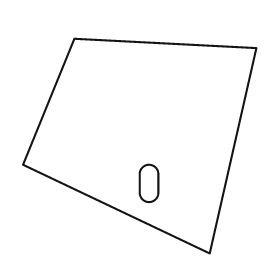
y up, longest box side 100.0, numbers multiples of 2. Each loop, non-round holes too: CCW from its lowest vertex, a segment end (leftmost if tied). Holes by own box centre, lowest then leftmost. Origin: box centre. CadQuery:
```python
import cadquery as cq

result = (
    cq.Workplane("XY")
    .moveTo(30.0, -46.0)
    .lineTo(50.0, 42.0)
    .lineTo(-28.0, 46.0)
    .lineTo(-50.0, -8.0)
    .close()
    .moveTo(0.0, -20.0)
    .threePointArc((4.0, -24.0), (8.0, -20.0))
    .lineTo(8.0, -12.0)
    .threePointArc((4.0, -8.0), (0.0, -12.0))
    .close()
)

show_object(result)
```